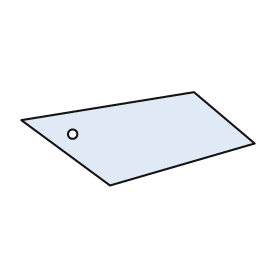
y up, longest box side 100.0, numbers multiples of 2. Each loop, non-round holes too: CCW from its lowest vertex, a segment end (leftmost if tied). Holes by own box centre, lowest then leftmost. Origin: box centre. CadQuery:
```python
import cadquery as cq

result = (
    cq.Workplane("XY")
    .moveTo(-12.0, -20.0)
    .lineTo(50.0, -2.0)
    .lineTo(24.0, 20.0)
    .lineTo(-50.0, 8.0)
    .close()
    .moveTo(-28.0, 2.0)
    .circle(2.0)
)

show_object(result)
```